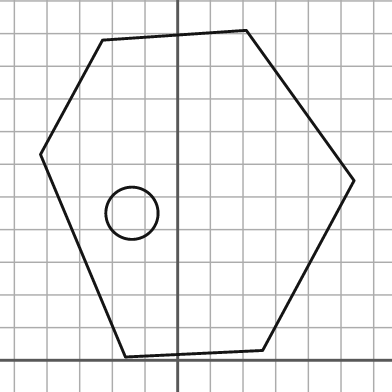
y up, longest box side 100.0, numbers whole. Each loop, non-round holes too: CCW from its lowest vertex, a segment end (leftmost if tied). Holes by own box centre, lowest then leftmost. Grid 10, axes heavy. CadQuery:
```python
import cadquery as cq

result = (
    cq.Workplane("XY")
    .moveTo(-16.0, 1.0)
    .lineTo(26.0, 3.0)
    .lineTo(54.0, 55.0)
    .lineTo(21.0, 101.0)
    .lineTo(-23.0, 98.0)
    .lineTo(-42.0, 63.0)
    .close()
    .moveTo(-14.0, 45.0)
    .circle(8.0)
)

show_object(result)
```